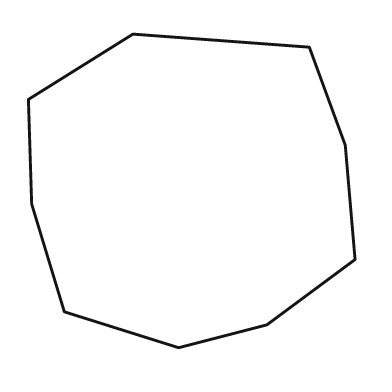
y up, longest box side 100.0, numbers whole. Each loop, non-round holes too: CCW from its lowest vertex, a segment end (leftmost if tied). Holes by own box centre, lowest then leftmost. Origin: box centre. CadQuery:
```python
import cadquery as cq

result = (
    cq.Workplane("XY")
    .moveTo(-4.0, -48.0)
    .lineTo(23.0, -41.0)
    .lineTo(50.0, -21.0)
    .lineTo(47.0, 14.0)
    .lineTo(36.0, 44.0)
    .lineTo(-18.0, 48.0)
    .lineTo(-50.0, 28.0)
    .lineTo(-49.0, -4.0)
    .lineTo(-39.0, -37.0)
    .close()
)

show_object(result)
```